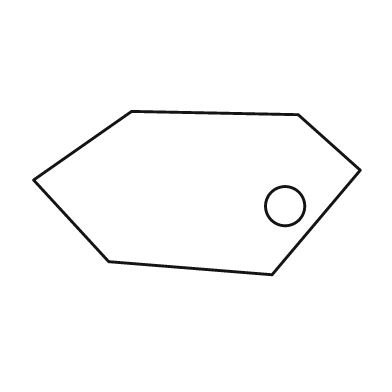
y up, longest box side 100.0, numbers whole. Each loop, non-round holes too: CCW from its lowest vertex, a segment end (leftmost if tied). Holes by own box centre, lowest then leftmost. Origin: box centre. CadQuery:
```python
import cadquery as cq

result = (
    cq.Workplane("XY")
    .moveTo(23.0, -25.0)
    .lineTo(50.0, 7.0)
    .lineTo(31.0, 24.0)
    .lineTo(-20.0, 25.0)
    .lineTo(-50.0, 4.0)
    .lineTo(-27.0, -21.0)
    .close()
    .moveTo(27.0, -4.0)
    .circle(6.0)
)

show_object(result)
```